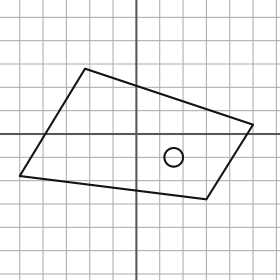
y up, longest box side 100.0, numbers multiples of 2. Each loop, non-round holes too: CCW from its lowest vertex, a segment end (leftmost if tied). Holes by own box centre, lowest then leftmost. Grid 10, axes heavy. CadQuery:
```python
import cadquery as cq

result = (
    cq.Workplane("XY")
    .moveTo(30.0, -28.0)
    .lineTo(50.0, 4.0)
    .lineTo(-22.0, 28.0)
    .lineTo(-50.0, -18.0)
    .close()
    .moveTo(16.0, -10.0)
    .circle(4.0)
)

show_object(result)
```